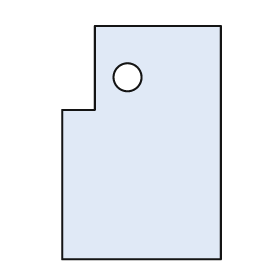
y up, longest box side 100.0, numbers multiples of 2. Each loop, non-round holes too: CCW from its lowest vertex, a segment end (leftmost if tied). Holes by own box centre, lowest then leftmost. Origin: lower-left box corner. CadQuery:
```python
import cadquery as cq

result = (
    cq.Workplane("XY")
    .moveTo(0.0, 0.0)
    .lineTo(68.0, 0.0)
    .lineTo(68.0, 100.0)
    .lineTo(14.0, 100.0)
    .lineTo(14.0, 64.0)
    .lineTo(0.0, 64.0)
    .close()
    .moveTo(28.0, 78.0)
    .circle(6.0)
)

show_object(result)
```